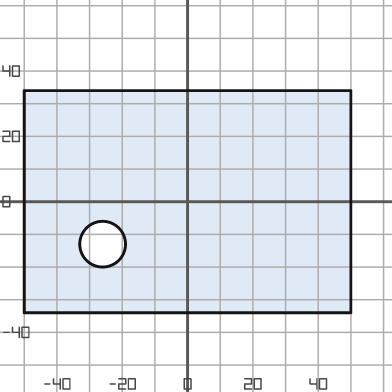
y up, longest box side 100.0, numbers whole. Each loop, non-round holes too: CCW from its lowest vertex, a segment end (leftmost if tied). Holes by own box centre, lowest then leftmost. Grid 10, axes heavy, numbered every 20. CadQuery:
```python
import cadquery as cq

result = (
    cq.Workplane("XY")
    .moveTo(-50.0, -34.0)
    .lineTo(50.0, -34.0)
    .lineTo(50.0, 34.0)
    .lineTo(-50.0, 34.0)
    .close()
    .moveTo(-26.0, -13.0)
    .circle(7.0)
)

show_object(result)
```